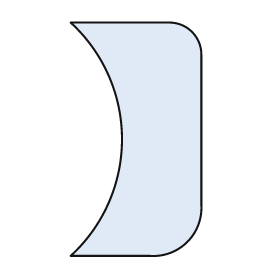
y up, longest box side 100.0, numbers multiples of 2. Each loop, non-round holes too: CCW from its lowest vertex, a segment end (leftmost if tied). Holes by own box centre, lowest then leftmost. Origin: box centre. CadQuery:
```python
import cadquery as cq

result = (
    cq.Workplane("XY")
    .moveTo(-28.0, -50.0)
    .lineTo(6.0, -50.0)
    .threePointArc((22.0, -44.0), (28.0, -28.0))
    .lineTo(28.0, 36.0)
    .threePointArc((24.0, 46.0), (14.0, 50.0))
    .lineTo(-28.0, 50.0)
    .threePointArc((-6.0, 0.0), (-28.0, -50.0))
    .close()
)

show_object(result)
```